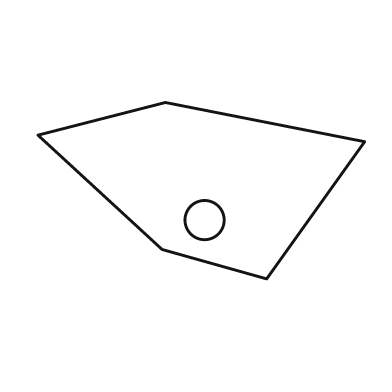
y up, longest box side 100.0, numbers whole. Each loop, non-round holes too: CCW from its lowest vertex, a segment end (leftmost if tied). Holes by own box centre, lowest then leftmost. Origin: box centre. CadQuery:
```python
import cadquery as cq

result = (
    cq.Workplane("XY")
    .moveTo(20.0, -27.0)
    .lineTo(50.0, 15.0)
    .lineTo(-11.0, 27.0)
    .lineTo(-50.0, 17.0)
    .lineTo(-12.0, -18.0)
    .close()
    .moveTo(1.0, -9.0)
    .circle(6.0)
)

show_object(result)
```